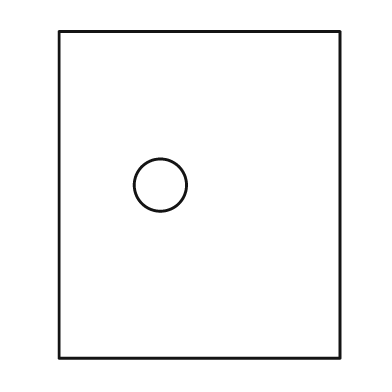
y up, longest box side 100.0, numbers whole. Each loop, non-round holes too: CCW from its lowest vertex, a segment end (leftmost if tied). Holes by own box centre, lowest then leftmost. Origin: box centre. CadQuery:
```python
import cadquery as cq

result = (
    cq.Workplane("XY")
    .moveTo(-43.0, -50.0)
    .lineTo(43.0, -50.0)
    .lineTo(43.0, 50.0)
    .lineTo(-43.0, 50.0)
    .close()
    .moveTo(-12.0, 3.0)
    .circle(8.0)
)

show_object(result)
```